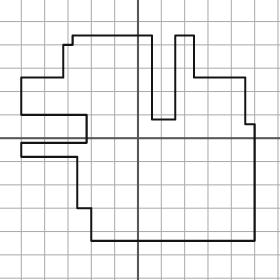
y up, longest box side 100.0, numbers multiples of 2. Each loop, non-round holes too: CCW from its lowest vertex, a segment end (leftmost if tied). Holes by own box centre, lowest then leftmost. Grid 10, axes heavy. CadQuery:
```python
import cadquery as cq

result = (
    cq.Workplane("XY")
    .moveTo(-20.0, -44.0)
    .lineTo(50.0, -44.0)
    .lineTo(50.0, 6.0)
    .lineTo(46.0, 6.0)
    .lineTo(46.0, 26.0)
    .lineTo(24.0, 26.0)
    .lineTo(24.0, 44.0)
    .lineTo(16.0, 44.0)
    .lineTo(16.0, 8.0)
    .lineTo(6.0, 8.0)
    .lineTo(6.0, 44.0)
    .lineTo(-28.0, 44.0)
    .lineTo(-28.0, 40.0)
    .lineTo(-32.0, 40.0)
    .lineTo(-32.0, 26.0)
    .lineTo(-50.0, 26.0)
    .lineTo(-50.0, 10.0)
    .lineTo(-22.0, 10.0)
    .lineTo(-22.0, -2.0)
    .lineTo(-50.0, -2.0)
    .lineTo(-50.0, -8.0)
    .lineTo(-26.0, -8.0)
    .lineTo(-26.0, -30.0)
    .lineTo(-20.0, -30.0)
    .close()
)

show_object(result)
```